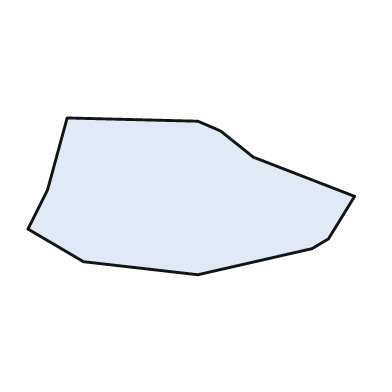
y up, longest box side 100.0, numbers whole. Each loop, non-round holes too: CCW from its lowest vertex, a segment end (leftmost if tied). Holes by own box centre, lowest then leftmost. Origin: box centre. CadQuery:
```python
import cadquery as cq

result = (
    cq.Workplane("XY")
    .moveTo(2.0, -24.0)
    .lineTo(37.0, -16.0)
    .lineTo(42.0, -13.0)
    .lineTo(50.0, 0.0)
    .lineTo(19.0, 12.0)
    .lineTo(9.0, 20.0)
    .lineTo(2.0, 23.0)
    .lineTo(-38.0, 24.0)
    .lineTo(-44.0, 2.0)
    .lineTo(-50.0, -10.0)
    .lineTo(-33.0, -20.0)
    .close()
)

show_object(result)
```